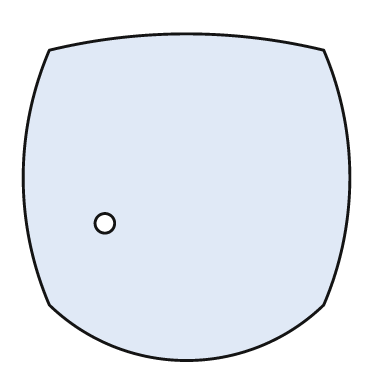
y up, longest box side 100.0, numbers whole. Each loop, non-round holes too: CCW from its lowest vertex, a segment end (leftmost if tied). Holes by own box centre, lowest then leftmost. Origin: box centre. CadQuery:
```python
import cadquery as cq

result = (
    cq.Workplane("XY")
    .moveTo(-42.0, -33.0)
    .threePointArc((0.0, -50.0), (42.0, -33.0))
    .threePointArc((50.0, 6.0), (42.0, 45.0))
    .threePointArc((0.0, 50.0), (-42.0, 45.0))
    .threePointArc((-50.0, 6.0), (-42.0, -33.0))
    .close()
    .moveTo(-25.0, -8.0)
    .circle(3.0)
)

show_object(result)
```